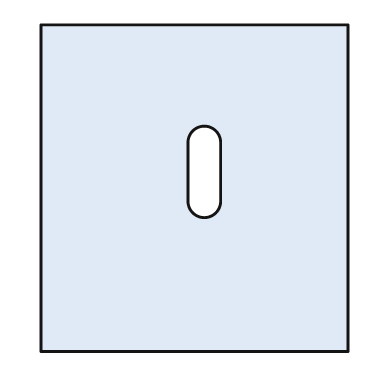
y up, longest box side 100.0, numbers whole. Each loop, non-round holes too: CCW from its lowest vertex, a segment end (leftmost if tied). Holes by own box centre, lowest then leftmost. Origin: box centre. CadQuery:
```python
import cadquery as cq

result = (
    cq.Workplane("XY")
    .moveTo(-47.0, -50.0)
    .lineTo(47.0, -50.0)
    .lineTo(47.0, 50.0)
    .lineTo(-47.0, 50.0)
    .close()
    .moveTo(-2.0, -4.0)
    .threePointArc((3.0, -9.0), (8.0, -4.0))
    .lineTo(8.0, 14.0)
    .threePointArc((3.0, 19.0), (-2.0, 14.0))
    .close()
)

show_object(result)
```